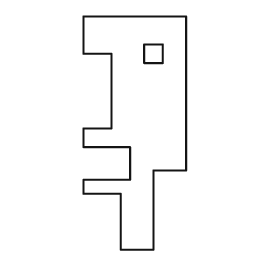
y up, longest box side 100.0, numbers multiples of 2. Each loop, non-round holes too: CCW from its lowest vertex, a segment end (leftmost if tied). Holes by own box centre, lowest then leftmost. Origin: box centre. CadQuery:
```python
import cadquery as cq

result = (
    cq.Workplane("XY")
    .moveTo(-6.0, -50.0)
    .lineTo(8.0, -50.0)
    .lineTo(8.0, -16.0)
    .lineTo(22.0, -16.0)
    .lineTo(22.0, 50.0)
    .lineTo(-22.0, 50.0)
    .lineTo(-22.0, 34.0)
    .lineTo(-10.0, 34.0)
    .lineTo(-10.0, 2.0)
    .lineTo(-22.0, 2.0)
    .lineTo(-22.0, -6.0)
    .lineTo(-2.0, -6.0)
    .lineTo(-2.0, -20.0)
    .lineTo(-22.0, -20.0)
    .lineTo(-22.0, -26.0)
    .lineTo(-6.0, -26.0)
    .close()
    .moveTo(4.0, 30.0)
    .lineTo(12.0, 30.0)
    .lineTo(12.0, 38.0)
    .lineTo(4.0, 38.0)
    .close()
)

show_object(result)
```